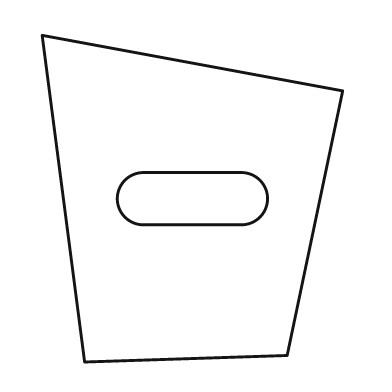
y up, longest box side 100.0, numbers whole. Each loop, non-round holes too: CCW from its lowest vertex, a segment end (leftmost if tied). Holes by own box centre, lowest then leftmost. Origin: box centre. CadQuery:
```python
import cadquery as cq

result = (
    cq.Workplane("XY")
    .moveTo(-33.0, -50.0)
    .lineTo(29.0, -48.0)
    .lineTo(46.0, 33.0)
    .lineTo(-46.0, 50.0)
    .close()
    .moveTo(-15.0, -8.0)
    .lineTo(15.0, -8.0)
    .threePointArc((23.0, 0.0), (15.0, 8.0))
    .lineTo(-15.0, 8.0)
    .threePointArc((-23.0, 0.0), (-15.0, -8.0))
    .close()
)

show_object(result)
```